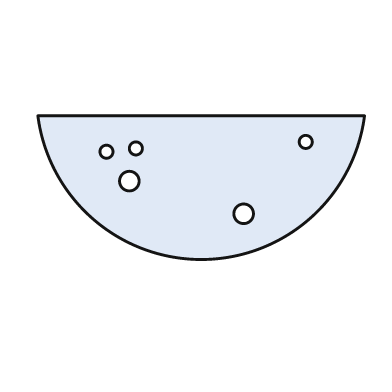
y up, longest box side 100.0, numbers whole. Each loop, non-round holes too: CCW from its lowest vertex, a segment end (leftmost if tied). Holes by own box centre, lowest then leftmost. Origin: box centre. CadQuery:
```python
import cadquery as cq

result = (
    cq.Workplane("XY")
    .moveTo(-50.0, 22.0)
    .threePointArc((0.0, -22.0), (50.0, 22.0))
    .close()
    .moveTo(13.0, -8.0)
    .circle(3.0)
    .moveTo(-22.0, 2.0)
    .circle(3.0)
    .moveTo(-29.0, 11.0)
    .circle(2.0)
    .moveTo(-20.0, 12.0)
    .circle(2.0)
    .moveTo(32.0, 14.0)
    .circle(2.0)
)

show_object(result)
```